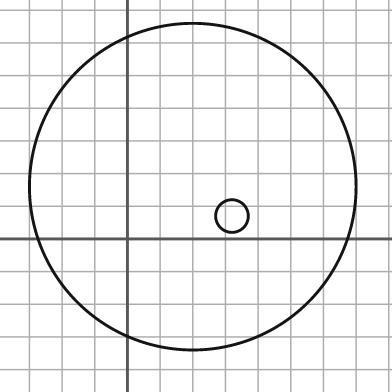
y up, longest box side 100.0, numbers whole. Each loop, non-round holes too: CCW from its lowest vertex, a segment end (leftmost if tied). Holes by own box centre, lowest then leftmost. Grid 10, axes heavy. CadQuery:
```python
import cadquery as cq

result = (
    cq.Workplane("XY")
    .moveTo(20.0, 16.0)
    .circle(50.0)
    .moveTo(32.0, 7.0)
    .circle(5.0)
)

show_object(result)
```